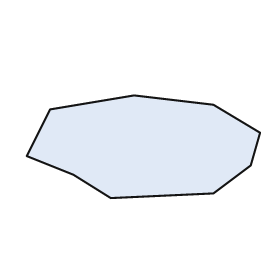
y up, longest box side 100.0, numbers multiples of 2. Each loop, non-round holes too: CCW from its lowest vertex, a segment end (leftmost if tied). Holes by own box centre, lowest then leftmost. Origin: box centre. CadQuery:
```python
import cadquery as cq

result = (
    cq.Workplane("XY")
    .moveTo(-14.0, -22.0)
    .lineTo(30.0, -20.0)
    .lineTo(46.0, -8.0)
    .lineTo(50.0, 6.0)
    .lineTo(30.0, 18.0)
    .lineTo(-4.0, 22.0)
    .lineTo(-40.0, 16.0)
    .lineTo(-50.0, -4.0)
    .lineTo(-30.0, -12.0)
    .close()
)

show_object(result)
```